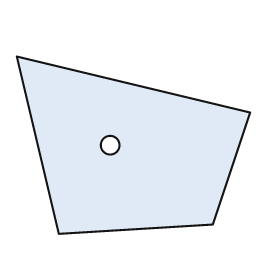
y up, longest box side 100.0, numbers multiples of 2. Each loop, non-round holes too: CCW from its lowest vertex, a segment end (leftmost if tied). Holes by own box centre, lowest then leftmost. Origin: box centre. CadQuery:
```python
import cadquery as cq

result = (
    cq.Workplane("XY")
    .moveTo(-32.0, -38.0)
    .lineTo(34.0, -34.0)
    .lineTo(50.0, 14.0)
    .lineTo(-50.0, 38.0)
    .close()
    .moveTo(-10.0, 0.0)
    .circle(4.0)
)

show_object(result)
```